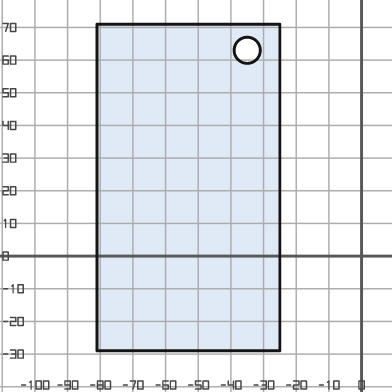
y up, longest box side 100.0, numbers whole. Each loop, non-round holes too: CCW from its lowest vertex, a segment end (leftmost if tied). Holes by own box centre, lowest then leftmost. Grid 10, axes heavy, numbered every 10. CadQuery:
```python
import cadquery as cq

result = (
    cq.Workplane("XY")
    .moveTo(-81.0, -29.0)
    .lineTo(-25.0, -29.0)
    .lineTo(-25.0, 71.0)
    .lineTo(-81.0, 71.0)
    .close()
    .moveTo(-35.0, 63.0)
    .circle(4.0)
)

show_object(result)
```